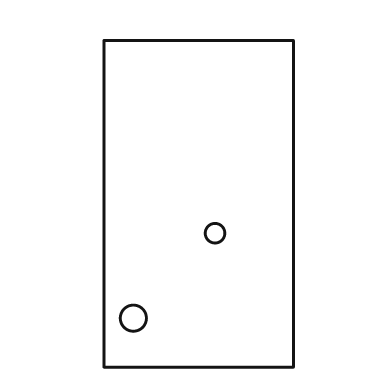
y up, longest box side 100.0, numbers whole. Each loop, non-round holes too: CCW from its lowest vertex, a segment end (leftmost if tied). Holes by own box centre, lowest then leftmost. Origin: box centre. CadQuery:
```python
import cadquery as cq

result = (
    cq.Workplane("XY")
    .moveTo(-29.0, -50.0)
    .lineTo(29.0, -50.0)
    .lineTo(29.0, 50.0)
    .lineTo(-29.0, 50.0)
    .close()
    .moveTo(-20.0, -35.0)
    .circle(4.0)
    .moveTo(5.0, -9.0)
    .circle(3.0)
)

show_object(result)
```